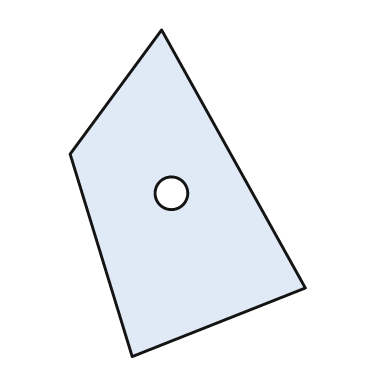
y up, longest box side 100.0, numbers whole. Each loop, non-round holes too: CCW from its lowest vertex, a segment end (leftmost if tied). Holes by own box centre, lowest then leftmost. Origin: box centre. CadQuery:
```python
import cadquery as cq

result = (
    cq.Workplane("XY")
    .moveTo(-17.0, -50.0)
    .lineTo(36.0, -29.0)
    .lineTo(-8.0, 50.0)
    .lineTo(-36.0, 12.0)
    .close()
    .moveTo(-5.0, 0.0)
    .circle(5.0)
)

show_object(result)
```